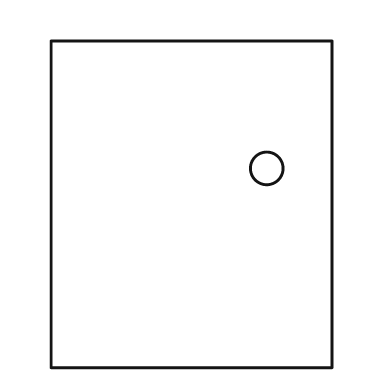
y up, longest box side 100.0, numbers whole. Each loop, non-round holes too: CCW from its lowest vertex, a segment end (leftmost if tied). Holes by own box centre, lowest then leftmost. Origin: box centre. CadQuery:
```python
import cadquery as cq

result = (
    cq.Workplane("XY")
    .moveTo(-43.0, -50.0)
    .lineTo(43.0, -50.0)
    .lineTo(43.0, 50.0)
    .lineTo(-43.0, 50.0)
    .close()
    .moveTo(23.0, 11.0)
    .circle(5.0)
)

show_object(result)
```